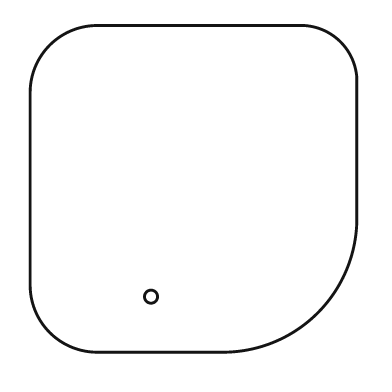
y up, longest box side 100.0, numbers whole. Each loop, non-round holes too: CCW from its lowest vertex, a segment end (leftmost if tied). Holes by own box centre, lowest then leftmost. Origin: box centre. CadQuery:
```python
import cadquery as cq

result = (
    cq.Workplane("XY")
    .moveTo(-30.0, -50.0)
    .lineTo(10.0, -50.0)
    .threePointArc((38.0, -38.0), (50.0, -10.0))
    .lineTo(50.0, 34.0)
    .threePointArc((45.0, 45.0), (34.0, 50.0))
    .lineTo(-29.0, 50.0)
    .threePointArc((-44.0, 44.0), (-50.0, 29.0))
    .lineTo(-50.0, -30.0)
    .threePointArc((-44.0, -44.0), (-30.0, -50.0))
    .close()
    .moveTo(-13.0, -33.0)
    .circle(2.0)
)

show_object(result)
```